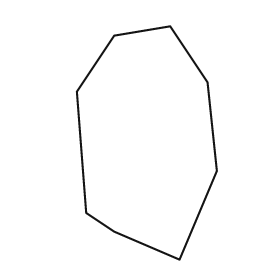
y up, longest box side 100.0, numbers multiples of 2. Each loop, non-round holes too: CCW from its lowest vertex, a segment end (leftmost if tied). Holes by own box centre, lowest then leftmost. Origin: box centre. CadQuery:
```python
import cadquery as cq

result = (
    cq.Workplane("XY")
    .moveTo(14.0, -50.0)
    .lineTo(30.0, -12.0)
    .lineTo(26.0, 26.0)
    .lineTo(10.0, 50.0)
    .lineTo(-14.0, 46.0)
    .lineTo(-30.0, 22.0)
    .lineTo(-26.0, -30.0)
    .lineTo(-14.0, -38.0)
    .close()
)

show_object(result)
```